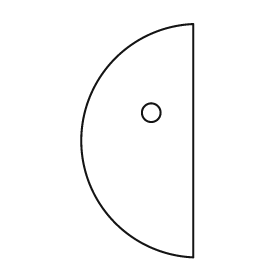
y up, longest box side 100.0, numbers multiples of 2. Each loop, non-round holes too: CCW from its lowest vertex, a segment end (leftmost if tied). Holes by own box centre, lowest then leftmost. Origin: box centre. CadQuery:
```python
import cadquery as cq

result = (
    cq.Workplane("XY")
    .moveTo(24.0, -50.0)
    .lineTo(24.0, 50.0)
    .threePointArc((-24.0, 0.0), (24.0, -50.0))
    .close()
    .moveTo(6.0, 12.0)
    .circle(4.0)
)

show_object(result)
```